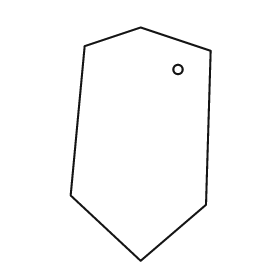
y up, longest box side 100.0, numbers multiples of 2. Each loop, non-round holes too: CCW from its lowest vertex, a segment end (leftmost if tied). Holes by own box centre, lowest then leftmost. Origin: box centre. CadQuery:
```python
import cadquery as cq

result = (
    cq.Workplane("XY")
    .moveTo(0.0, -50.0)
    .lineTo(28.0, -26.0)
    .lineTo(30.0, 40.0)
    .lineTo(0.0, 50.0)
    .lineTo(-24.0, 42.0)
    .lineTo(-30.0, -22.0)
    .close()
    .moveTo(16.0, 32.0)
    .circle(2.0)
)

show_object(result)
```